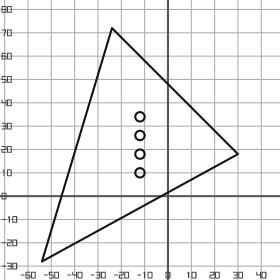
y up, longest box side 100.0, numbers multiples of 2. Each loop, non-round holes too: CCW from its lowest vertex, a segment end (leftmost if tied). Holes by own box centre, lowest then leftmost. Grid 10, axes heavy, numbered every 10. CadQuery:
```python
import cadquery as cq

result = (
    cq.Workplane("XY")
    .moveTo(-54.0, -28.0)
    .lineTo(30.0, 18.0)
    .lineTo(-24.0, 72.0)
    .close()
    .moveTo(-12.0, 10.0)
    .circle(2.0)
    .moveTo(-12.0, 18.0)
    .circle(2.0)
    .moveTo(-12.0, 26.0)
    .circle(2.0)
    .moveTo(-12.0, 34.0)
    .circle(2.0)
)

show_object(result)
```